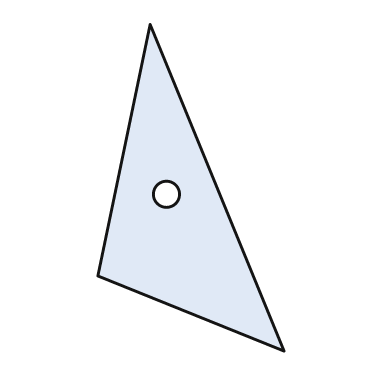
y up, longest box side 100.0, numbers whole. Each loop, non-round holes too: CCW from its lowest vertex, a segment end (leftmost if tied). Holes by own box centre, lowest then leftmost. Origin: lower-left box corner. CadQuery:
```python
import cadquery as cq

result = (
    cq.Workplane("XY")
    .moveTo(57.0, 0.0)
    .lineTo(16.0, 100.0)
    .lineTo(0.0, 23.0)
    .close()
    .moveTo(21.0, 48.0)
    .circle(4.0)
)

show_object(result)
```